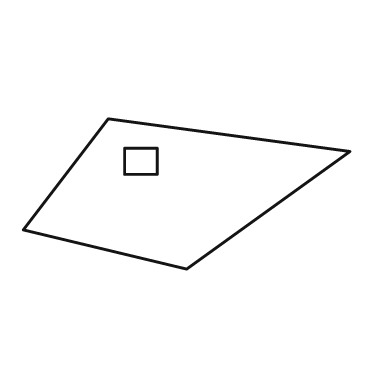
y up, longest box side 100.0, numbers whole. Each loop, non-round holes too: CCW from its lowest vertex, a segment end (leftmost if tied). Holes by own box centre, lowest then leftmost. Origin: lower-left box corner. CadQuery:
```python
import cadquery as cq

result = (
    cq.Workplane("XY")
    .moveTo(50.0, 0.0)
    .lineTo(100.0, 36.0)
    .lineTo(26.0, 46.0)
    .lineTo(0.0, 12.0)
    .close()
    .moveTo(31.0, 29.0)
    .lineTo(41.0, 29.0)
    .lineTo(41.0, 37.0)
    .lineTo(31.0, 37.0)
    .close()
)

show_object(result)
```